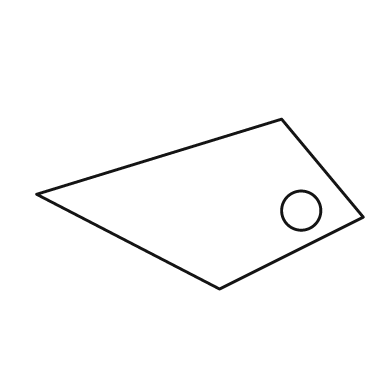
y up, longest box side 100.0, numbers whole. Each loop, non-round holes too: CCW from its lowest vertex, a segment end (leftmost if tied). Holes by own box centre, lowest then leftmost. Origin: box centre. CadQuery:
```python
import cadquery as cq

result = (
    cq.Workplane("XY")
    .moveTo(6.0, -26.0)
    .lineTo(50.0, -4.0)
    .lineTo(25.0, 26.0)
    .lineTo(-50.0, 3.0)
    .close()
    .moveTo(31.0, -2.0)
    .circle(6.0)
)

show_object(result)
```